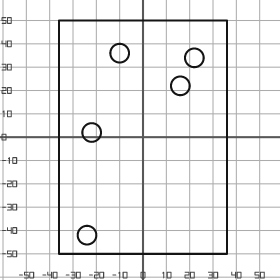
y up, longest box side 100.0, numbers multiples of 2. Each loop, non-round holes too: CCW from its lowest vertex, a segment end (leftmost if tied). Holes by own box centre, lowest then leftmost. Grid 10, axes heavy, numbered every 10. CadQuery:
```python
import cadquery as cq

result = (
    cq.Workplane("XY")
    .moveTo(-36.0, -50.0)
    .lineTo(36.0, -50.0)
    .lineTo(36.0, 50.0)
    .lineTo(-36.0, 50.0)
    .close()
    .moveTo(-24.0, -42.0)
    .circle(4.0)
    .moveTo(-22.0, 2.0)
    .circle(4.0)
    .moveTo(16.0, 22.0)
    .circle(4.0)
    .moveTo(22.0, 34.0)
    .circle(4.0)
    .moveTo(-10.0, 36.0)
    .circle(4.0)
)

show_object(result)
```